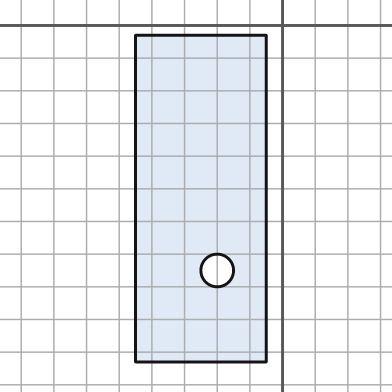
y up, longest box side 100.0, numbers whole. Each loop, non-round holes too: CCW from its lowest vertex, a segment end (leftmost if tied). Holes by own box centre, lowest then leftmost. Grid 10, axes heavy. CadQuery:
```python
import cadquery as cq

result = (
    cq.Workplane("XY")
    .moveTo(-45.0, -103.0)
    .lineTo(-5.0, -103.0)
    .lineTo(-5.0, -3.0)
    .lineTo(-45.0, -3.0)
    .close()
    .moveTo(-20.0, -75.0)
    .circle(5.0)
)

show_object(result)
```